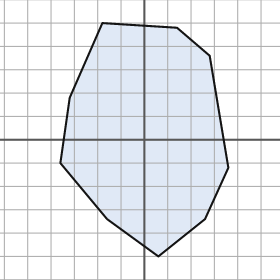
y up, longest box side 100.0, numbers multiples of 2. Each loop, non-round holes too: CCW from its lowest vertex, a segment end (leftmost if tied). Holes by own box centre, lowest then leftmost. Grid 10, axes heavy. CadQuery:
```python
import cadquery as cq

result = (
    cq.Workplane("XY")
    .moveTo(6.0, -50.0)
    .lineTo(26.0, -34.0)
    .lineTo(36.0, -12.0)
    .lineTo(28.0, 36.0)
    .lineTo(14.0, 48.0)
    .lineTo(-18.0, 50.0)
    .lineTo(-32.0, 18.0)
    .lineTo(-36.0, -10.0)
    .lineTo(-16.0, -34.0)
    .close()
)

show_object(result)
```